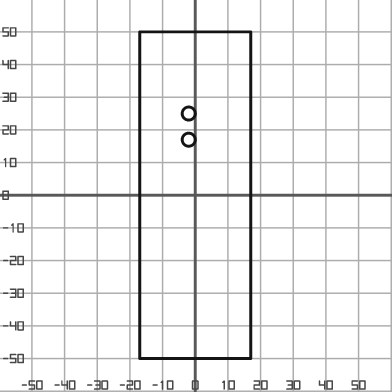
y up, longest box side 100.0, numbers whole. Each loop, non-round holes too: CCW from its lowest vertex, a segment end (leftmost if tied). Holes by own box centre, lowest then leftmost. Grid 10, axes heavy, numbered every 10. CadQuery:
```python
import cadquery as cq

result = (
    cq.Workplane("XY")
    .moveTo(-17.0, -50.0)
    .lineTo(17.0, -50.0)
    .lineTo(17.0, 50.0)
    .lineTo(-17.0, 50.0)
    .close()
    .moveTo(-2.0, 17.0)
    .circle(2.0)
    .moveTo(-2.0, 25.0)
    .circle(2.0)
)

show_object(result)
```